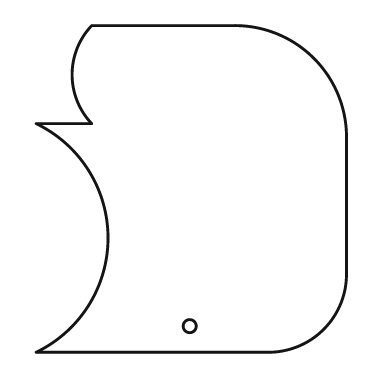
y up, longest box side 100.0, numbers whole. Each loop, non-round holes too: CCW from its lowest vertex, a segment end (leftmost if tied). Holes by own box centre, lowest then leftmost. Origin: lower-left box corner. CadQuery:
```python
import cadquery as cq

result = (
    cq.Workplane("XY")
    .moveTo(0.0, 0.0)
    .lineTo(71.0, 0.0)
    .threePointArc((88.0, 7.0), (95.0, 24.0))
    .lineTo(95.0, 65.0)
    .threePointArc((85.0, 90.0), (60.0, 100.0))
    .lineTo(17.0, 100.0)
    .threePointArc((11.0, 85.0), (17.0, 70.0))
    .lineTo(0.0, 70.0)
    .threePointArc((22.0, 35.0), (0.0, 0.0))
    .close()
    .moveTo(47.0, 8.0)
    .circle(2.0)
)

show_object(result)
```